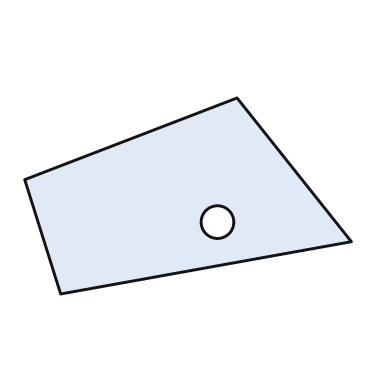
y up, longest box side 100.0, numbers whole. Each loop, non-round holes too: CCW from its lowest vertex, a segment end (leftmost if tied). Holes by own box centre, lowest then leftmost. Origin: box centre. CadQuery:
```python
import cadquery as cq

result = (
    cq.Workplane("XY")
    .moveTo(-39.0, -30.0)
    .lineTo(50.0, -14.0)
    .lineTo(15.0, 30.0)
    .lineTo(-50.0, 5.0)
    .close()
    .moveTo(9.0, -8.0)
    .circle(5.0)
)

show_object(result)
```